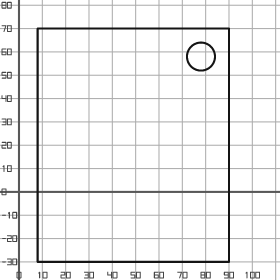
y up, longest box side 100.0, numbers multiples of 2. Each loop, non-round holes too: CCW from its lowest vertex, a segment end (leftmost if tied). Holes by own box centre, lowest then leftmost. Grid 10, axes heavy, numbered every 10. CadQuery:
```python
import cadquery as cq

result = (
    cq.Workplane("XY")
    .moveTo(8.0, -30.0)
    .lineTo(90.0, -30.0)
    .lineTo(90.0, 70.0)
    .lineTo(8.0, 70.0)
    .close()
    .moveTo(78.0, 58.0)
    .circle(6.0)
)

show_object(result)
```